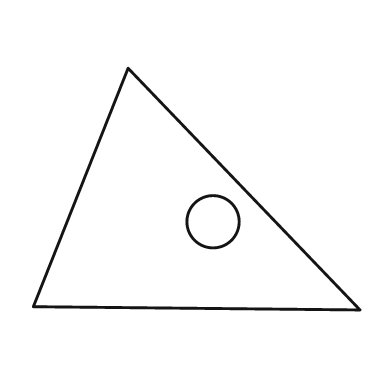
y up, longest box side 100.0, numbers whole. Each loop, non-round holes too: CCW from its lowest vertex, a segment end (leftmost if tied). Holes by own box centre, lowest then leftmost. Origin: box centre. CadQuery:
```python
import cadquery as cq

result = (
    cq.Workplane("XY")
    .moveTo(50.0, -37.0)
    .lineTo(-21.0, 37.0)
    .lineTo(-50.0, -36.0)
    .close()
    .moveTo(5.0, -10.0)
    .circle(8.0)
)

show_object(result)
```